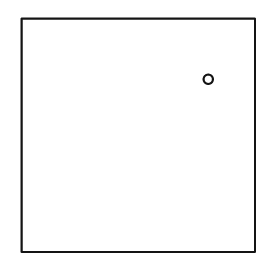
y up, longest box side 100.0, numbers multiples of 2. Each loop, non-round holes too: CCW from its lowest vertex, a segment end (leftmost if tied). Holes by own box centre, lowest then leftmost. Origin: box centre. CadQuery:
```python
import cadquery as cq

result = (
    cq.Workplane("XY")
    .moveTo(-50.0, -50.0)
    .lineTo(50.0, -50.0)
    .lineTo(50.0, 50.0)
    .lineTo(-50.0, 50.0)
    .close()
    .moveTo(30.0, 24.0)
    .circle(2.0)
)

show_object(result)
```